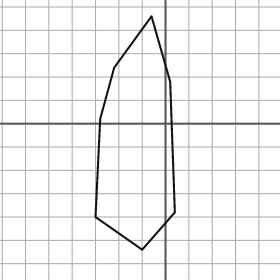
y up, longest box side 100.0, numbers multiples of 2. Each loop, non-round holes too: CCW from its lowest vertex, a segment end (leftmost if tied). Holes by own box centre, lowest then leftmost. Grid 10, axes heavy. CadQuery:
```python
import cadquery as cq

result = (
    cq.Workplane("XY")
    .moveTo(-10.0, -54.0)
    .lineTo(4.0, -38.0)
    .lineTo(2.0, 18.0)
    .lineTo(-6.0, 46.0)
    .lineTo(-22.0, 24.0)
    .lineTo(-28.0, 2.0)
    .lineTo(-30.0, -40.0)
    .close()
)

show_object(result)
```